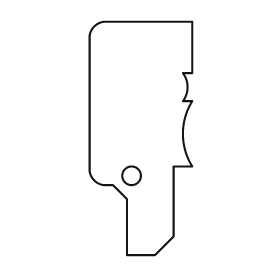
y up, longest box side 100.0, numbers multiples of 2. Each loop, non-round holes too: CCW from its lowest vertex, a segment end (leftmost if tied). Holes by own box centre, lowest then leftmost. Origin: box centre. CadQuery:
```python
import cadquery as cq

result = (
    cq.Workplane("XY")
    .moveTo(-6.0, -50.0)
    .lineTo(6.0, -50.0)
    .lineTo(14.0, -42.0)
    .lineTo(14.0, -12.0)
    .lineTo(22.0, -12.0)
    .threePointArc((18.0, 2.0), (22.0, 16.0))
    .lineTo(18.0, 16.0)
    .threePointArc((20.0, 22.0), (18.0, 28.0))
    .lineTo(22.0, 28.0)
    .lineTo(22.0, 50.0)
    .lineTo(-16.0, 50.0)
    .threePointArc((-20.0, 48.0), (-22.0, 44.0))
    .lineTo(-22.0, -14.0)
    .threePointArc((-20.0, -18.0), (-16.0, -20.0))
    .lineTo(-12.0, -20.0)
    .lineTo(-6.0, -26.0)
    .close()
    .moveTo(-4.0, -16.0)
    .circle(4.0)
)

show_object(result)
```